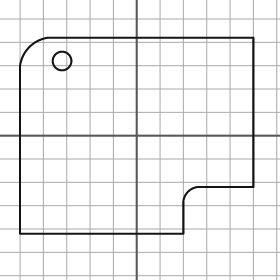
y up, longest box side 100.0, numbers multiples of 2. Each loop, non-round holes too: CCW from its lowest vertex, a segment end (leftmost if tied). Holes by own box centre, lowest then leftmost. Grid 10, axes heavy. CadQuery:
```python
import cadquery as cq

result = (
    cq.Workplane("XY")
    .moveTo(-50.0, -42.0)
    .lineTo(20.0, -42.0)
    .lineTo(20.0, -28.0)
    .threePointArc((22.0, -24.0), (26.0, -22.0))
    .lineTo(50.0, -22.0)
    .lineTo(50.0, 42.0)
    .lineTo(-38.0, 42.0)
    .threePointArc((-46.0, 38.0), (-50.0, 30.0))
    .close()
    .moveTo(-32.0, 32.0)
    .circle(4.0)
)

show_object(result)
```